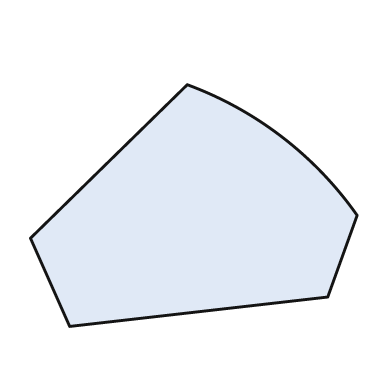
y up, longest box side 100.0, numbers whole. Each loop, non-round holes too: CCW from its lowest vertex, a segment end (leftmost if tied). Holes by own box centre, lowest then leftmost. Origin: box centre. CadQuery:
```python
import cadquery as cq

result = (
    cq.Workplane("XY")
    .moveTo(-38.0, -37.0)
    .lineTo(41.0, -28.0)
    .lineTo(50.0, -3.0)
    .threePointArc((27.0, 21.0), (-2.0, 37.0))
    .lineTo(-50.0, -10.0)
    .close()
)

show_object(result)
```